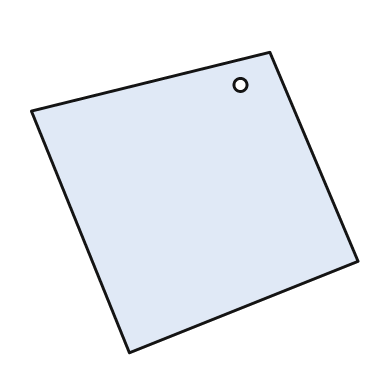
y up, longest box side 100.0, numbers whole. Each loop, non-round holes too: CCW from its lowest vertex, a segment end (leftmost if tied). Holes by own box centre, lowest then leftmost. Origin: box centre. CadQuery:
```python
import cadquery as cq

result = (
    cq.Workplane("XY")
    .moveTo(-20.0, -46.0)
    .lineTo(50.0, -18.0)
    .lineTo(23.0, 46.0)
    .lineTo(-50.0, 28.0)
    .close()
    .moveTo(14.0, 36.0)
    .circle(2.0)
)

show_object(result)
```